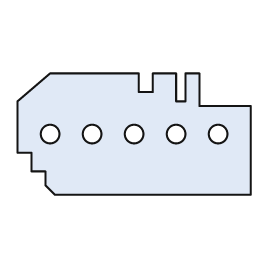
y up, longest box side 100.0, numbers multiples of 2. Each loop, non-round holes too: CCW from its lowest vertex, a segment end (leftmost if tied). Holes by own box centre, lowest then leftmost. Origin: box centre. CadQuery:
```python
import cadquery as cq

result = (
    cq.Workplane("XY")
    .moveTo(-34.0, -26.0)
    .lineTo(50.0, -26.0)
    .lineTo(50.0, 12.0)
    .lineTo(28.0, 12.0)
    .lineTo(28.0, 26.0)
    .lineTo(22.0, 26.0)
    .lineTo(22.0, 14.0)
    .lineTo(18.0, 14.0)
    .lineTo(18.0, 26.0)
    .lineTo(8.0, 26.0)
    .lineTo(8.0, 18.0)
    .lineTo(2.0, 18.0)
    .lineTo(2.0, 26.0)
    .lineTo(-36.0, 26.0)
    .lineTo(-50.0, 14.0)
    .lineTo(-50.0, -8.0)
    .lineTo(-44.0, -8.0)
    .lineTo(-44.0, -16.0)
    .lineTo(-38.0, -16.0)
    .lineTo(-38.0, -22.0)
    .close()
    .moveTo(-36.0, 0.0)
    .circle(4.0)
    .moveTo(-18.0, 0.0)
    .circle(4.0)
    .moveTo(0.0, 0.0)
    .circle(4.0)
    .moveTo(18.0, 0.0)
    .circle(4.0)
    .moveTo(36.0, 0.0)
    .circle(4.0)
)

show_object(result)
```